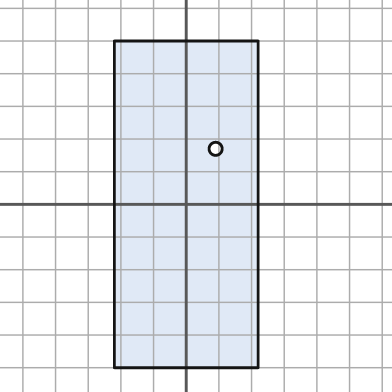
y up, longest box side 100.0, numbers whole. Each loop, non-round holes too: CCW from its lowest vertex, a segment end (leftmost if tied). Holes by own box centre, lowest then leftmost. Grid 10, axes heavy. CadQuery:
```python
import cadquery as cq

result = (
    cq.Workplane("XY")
    .moveTo(-22.0, -50.0)
    .lineTo(22.0, -50.0)
    .lineTo(22.0, 50.0)
    .lineTo(-22.0, 50.0)
    .close()
    .moveTo(9.0, 17.0)
    .circle(2.0)
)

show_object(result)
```